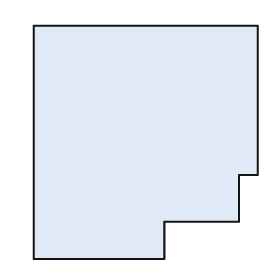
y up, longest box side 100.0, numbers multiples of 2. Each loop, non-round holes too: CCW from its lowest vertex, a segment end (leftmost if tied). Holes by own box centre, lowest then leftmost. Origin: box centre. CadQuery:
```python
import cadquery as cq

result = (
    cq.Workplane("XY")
    .moveTo(-48.0, -50.0)
    .lineTo(8.0, -50.0)
    .lineTo(8.0, -34.0)
    .lineTo(40.0, -34.0)
    .lineTo(40.0, -14.0)
    .lineTo(48.0, -14.0)
    .lineTo(48.0, 50.0)
    .lineTo(-48.0, 50.0)
    .close()
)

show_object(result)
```